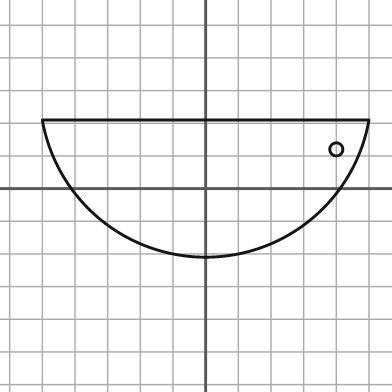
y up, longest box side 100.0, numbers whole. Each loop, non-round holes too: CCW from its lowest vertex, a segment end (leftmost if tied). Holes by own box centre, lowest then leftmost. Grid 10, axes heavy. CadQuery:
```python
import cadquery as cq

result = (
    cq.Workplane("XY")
    .moveTo(-50.0, 21.0)
    .threePointArc((0.0, -21.0), (50.0, 21.0))
    .close()
    .moveTo(40.0, 12.0)
    .circle(2.0)
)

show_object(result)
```